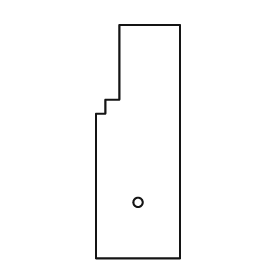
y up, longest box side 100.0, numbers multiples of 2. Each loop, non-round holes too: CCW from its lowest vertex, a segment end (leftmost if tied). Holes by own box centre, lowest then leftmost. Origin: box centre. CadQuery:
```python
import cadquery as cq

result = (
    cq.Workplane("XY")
    .moveTo(-18.0, -50.0)
    .lineTo(18.0, -50.0)
    .lineTo(18.0, 50.0)
    .lineTo(-8.0, 50.0)
    .lineTo(-8.0, 18.0)
    .lineTo(-14.0, 18.0)
    .lineTo(-14.0, 12.0)
    .lineTo(-18.0, 12.0)
    .close()
    .moveTo(0.0, -26.0)
    .circle(2.0)
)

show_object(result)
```